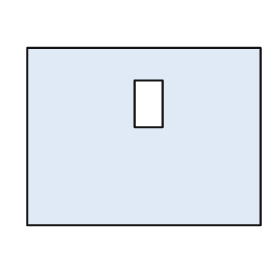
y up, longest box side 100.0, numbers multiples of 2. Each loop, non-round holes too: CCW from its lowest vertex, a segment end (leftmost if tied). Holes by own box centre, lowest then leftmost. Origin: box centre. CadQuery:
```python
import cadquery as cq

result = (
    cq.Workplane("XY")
    .moveTo(-50.0, -38.0)
    .lineTo(50.0, -38.0)
    .lineTo(50.0, 38.0)
    .lineTo(-50.0, 38.0)
    .close()
    .moveTo(-4.0, 4.0)
    .lineTo(8.0, 4.0)
    .lineTo(8.0, 24.0)
    .lineTo(-4.0, 24.0)
    .close()
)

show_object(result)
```